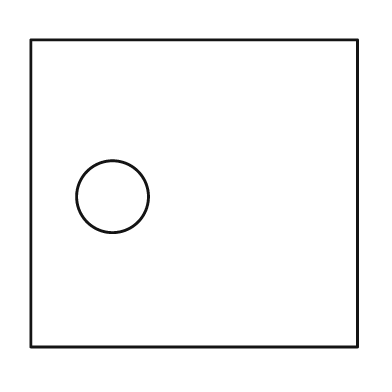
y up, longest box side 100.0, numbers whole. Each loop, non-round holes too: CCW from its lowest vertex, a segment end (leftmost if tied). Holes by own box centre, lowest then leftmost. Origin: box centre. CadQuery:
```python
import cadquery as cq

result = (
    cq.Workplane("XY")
    .moveTo(-50.0, -47.0)
    .lineTo(50.0, -47.0)
    .lineTo(50.0, 47.0)
    .lineTo(-50.0, 47.0)
    .close()
    .moveTo(-25.0, -1.0)
    .circle(11.0)
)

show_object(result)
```